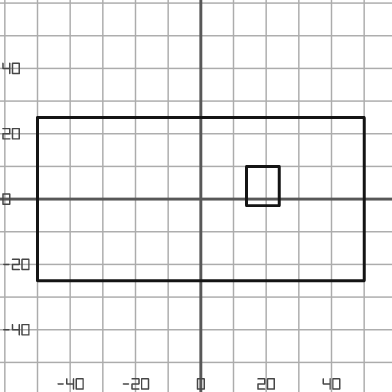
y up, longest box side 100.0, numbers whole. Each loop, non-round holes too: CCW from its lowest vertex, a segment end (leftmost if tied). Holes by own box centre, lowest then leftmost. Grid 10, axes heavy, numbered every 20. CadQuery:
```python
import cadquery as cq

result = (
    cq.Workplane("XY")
    .moveTo(-50.0, -25.0)
    .lineTo(50.0, -25.0)
    .lineTo(50.0, 25.0)
    .lineTo(-50.0, 25.0)
    .close()
    .moveTo(14.0, -2.0)
    .lineTo(24.0, -2.0)
    .lineTo(24.0, 10.0)
    .lineTo(14.0, 10.0)
    .close()
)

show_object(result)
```